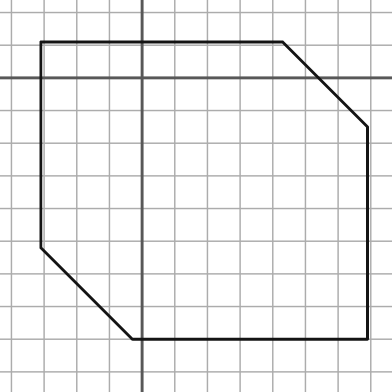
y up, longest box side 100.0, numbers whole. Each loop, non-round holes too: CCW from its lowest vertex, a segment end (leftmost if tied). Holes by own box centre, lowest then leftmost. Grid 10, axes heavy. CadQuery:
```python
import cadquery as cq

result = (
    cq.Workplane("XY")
    .moveTo(-3.0, -80.0)
    .lineTo(69.0, -80.0)
    .lineTo(69.0, -15.0)
    .lineTo(43.0, 11.0)
    .lineTo(-31.0, 11.0)
    .lineTo(-31.0, -52.0)
    .close()
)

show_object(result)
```